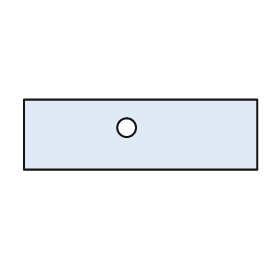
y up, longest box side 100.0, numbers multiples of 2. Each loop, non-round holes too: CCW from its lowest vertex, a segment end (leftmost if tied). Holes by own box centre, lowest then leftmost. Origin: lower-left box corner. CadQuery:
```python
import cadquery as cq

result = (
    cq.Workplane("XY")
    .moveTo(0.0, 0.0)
    .lineTo(100.0, 0.0)
    .lineTo(100.0, 30.0)
    .lineTo(0.0, 30.0)
    .close()
    .moveTo(44.0, 18.0)
    .circle(4.0)
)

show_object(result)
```